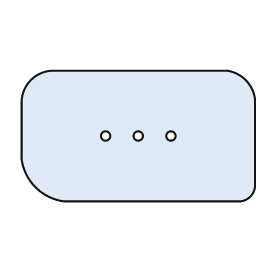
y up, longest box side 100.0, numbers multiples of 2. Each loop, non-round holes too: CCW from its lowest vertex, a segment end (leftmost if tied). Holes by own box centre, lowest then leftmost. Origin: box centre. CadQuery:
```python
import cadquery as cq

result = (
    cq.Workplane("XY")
    .moveTo(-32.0, -28.0)
    .lineTo(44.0, -28.0)
    .threePointArc((48.0, -26.0), (50.0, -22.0))
    .lineTo(50.0, 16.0)
    .threePointArc((46.0, 24.0), (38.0, 28.0))
    .lineTo(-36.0, 28.0)
    .threePointArc((-46.0, 24.0), (-50.0, 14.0))
    .lineTo(-50.0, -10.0)
    .threePointArc((-44.0, -22.0), (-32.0, -28.0))
    .close()
    .moveTo(-14.0, 0.0)
    .circle(2.0)
    .moveTo(0.0, 0.0)
    .circle(2.0)
    .moveTo(14.0, 0.0)
    .circle(2.0)
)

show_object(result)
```